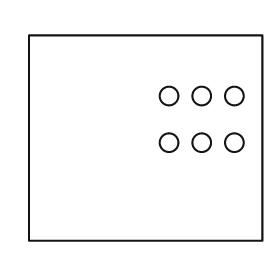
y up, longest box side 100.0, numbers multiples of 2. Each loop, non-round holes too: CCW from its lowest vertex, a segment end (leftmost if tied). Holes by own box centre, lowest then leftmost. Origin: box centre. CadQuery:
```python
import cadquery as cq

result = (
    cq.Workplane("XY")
    .moveTo(-50.0, -44.0)
    .lineTo(50.0, -44.0)
    .lineTo(50.0, 44.0)
    .lineTo(-50.0, 44.0)
    .close()
    .moveTo(10.0, -2.0)
    .circle(4.0)
    .moveTo(24.0, -2.0)
    .circle(4.0)
    .moveTo(38.0, -2.0)
    .circle(4.0)
    .moveTo(10.0, 18.0)
    .circle(4.0)
    .moveTo(24.0, 18.0)
    .circle(4.0)
    .moveTo(38.0, 18.0)
    .circle(4.0)
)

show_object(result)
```